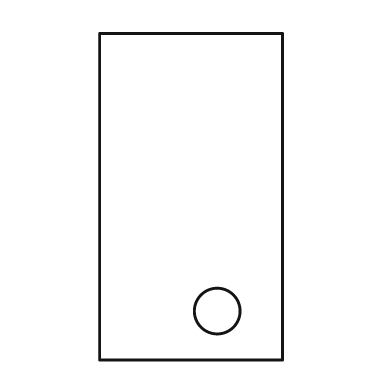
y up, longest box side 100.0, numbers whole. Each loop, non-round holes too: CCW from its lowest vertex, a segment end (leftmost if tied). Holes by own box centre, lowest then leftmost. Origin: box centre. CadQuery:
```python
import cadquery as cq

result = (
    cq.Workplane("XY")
    .moveTo(-28.0, -50.0)
    .lineTo(28.0, -50.0)
    .lineTo(28.0, 50.0)
    .lineTo(-28.0, 50.0)
    .close()
    .moveTo(8.0, -35.0)
    .circle(7.0)
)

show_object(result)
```